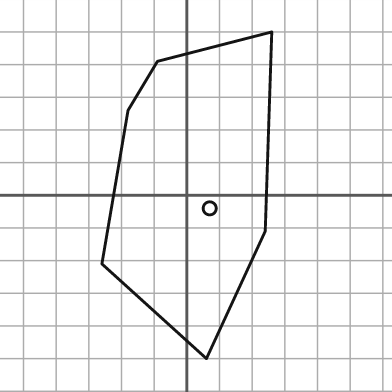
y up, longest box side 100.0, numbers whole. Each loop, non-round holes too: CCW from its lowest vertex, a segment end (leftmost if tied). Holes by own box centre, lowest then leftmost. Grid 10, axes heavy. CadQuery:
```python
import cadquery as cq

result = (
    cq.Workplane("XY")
    .moveTo(6.0, -50.0)
    .lineTo(24.0, -11.0)
    .lineTo(26.0, 50.0)
    .lineTo(-9.0, 41.0)
    .lineTo(-18.0, 26.0)
    .lineTo(-26.0, -21.0)
    .close()
    .moveTo(7.0, -4.0)
    .circle(2.0)
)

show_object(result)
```